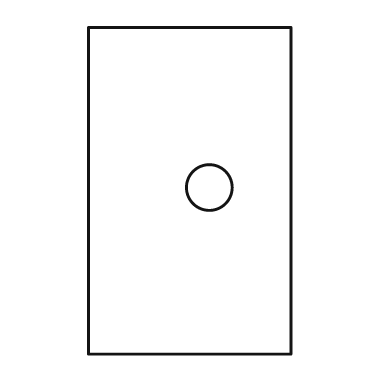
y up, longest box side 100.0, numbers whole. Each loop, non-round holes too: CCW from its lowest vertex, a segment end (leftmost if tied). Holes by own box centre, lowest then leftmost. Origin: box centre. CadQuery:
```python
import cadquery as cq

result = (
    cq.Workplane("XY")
    .moveTo(-31.0, -50.0)
    .lineTo(31.0, -50.0)
    .lineTo(31.0, 50.0)
    .lineTo(-31.0, 50.0)
    .close()
    .moveTo(6.0, 1.0)
    .circle(7.0)
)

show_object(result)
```